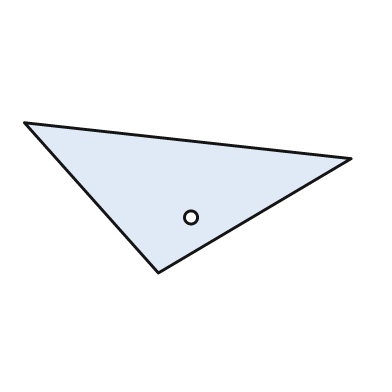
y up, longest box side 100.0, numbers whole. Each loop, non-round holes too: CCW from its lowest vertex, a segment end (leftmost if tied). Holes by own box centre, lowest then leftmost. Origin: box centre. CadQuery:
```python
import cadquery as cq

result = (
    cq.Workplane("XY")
    .moveTo(-9.0, -23.0)
    .lineTo(50.0, 12.0)
    .lineTo(-50.0, 23.0)
    .close()
    .moveTo(1.0, -6.0)
    .circle(2.0)
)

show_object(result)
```